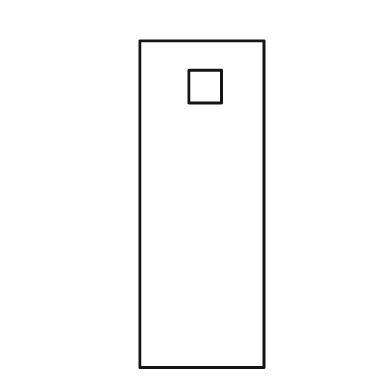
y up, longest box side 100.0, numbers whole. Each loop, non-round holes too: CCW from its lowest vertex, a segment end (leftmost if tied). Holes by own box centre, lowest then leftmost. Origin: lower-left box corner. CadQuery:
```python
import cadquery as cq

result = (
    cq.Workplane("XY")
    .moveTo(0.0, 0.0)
    .lineTo(38.0, 0.0)
    .lineTo(38.0, 100.0)
    .lineTo(0.0, 100.0)
    .close()
    .moveTo(15.0, 81.0)
    .lineTo(25.0, 81.0)
    .lineTo(25.0, 91.0)
    .lineTo(15.0, 91.0)
    .close()
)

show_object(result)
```